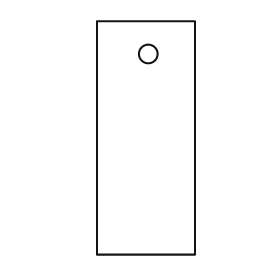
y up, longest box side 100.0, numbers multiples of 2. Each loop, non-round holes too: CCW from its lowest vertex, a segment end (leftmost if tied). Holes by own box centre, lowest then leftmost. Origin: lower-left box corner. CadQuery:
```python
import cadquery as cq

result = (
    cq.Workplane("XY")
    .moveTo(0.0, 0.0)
    .lineTo(42.0, 0.0)
    .lineTo(42.0, 100.0)
    .lineTo(0.0, 100.0)
    .close()
    .moveTo(22.0, 86.0)
    .circle(4.0)
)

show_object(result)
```